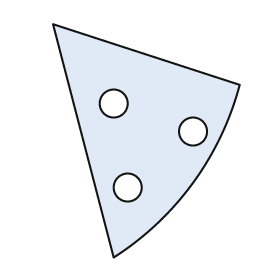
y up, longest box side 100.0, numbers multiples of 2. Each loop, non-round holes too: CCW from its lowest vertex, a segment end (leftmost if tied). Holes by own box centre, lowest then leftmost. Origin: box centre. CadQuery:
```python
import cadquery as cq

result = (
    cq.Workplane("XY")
    .moveTo(-14.0, -50.0)
    .threePointArc((20.0, -18.0), (40.0, 24.0))
    .lineTo(-40.0, 50.0)
    .close()
    .moveTo(-8.0, -20.0)
    .circle(6.0)
    .moveTo(20.0, 4.0)
    .circle(6.0)
    .moveTo(-14.0, 16.0)
    .circle(6.0)
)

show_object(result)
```